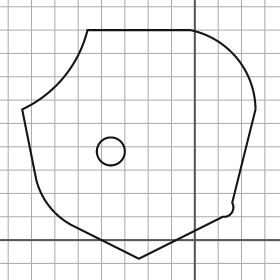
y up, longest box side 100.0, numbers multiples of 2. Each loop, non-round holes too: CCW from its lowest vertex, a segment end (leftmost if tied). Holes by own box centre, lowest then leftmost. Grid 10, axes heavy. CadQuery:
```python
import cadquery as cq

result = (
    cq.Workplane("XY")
    .moveTo(-24.0, -8.0)
    .lineTo(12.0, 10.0)
    .threePointArc((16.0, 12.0), (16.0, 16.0))
    .lineTo(26.0, 56.0)
    .threePointArc((18.0, 78.0), (-2.0, 90.0))
    .lineTo(-46.0, 90.0)
    .threePointArc((-56.0, 70.0), (-74.0, 56.0))
    .lineTo(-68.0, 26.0)
    .threePointArc((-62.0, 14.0), (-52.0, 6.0))
    .close()
    .moveTo(-36.0, 38.0)
    .circle(6.0)
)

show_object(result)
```